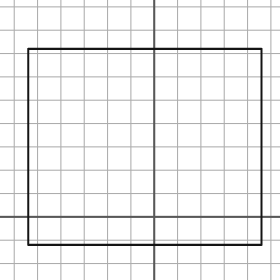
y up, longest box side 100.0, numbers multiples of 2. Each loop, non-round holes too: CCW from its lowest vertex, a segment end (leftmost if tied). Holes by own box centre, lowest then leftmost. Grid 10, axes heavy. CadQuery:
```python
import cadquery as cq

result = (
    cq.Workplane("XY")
    .moveTo(-54.0, -12.0)
    .lineTo(46.0, -12.0)
    .lineTo(46.0, 72.0)
    .lineTo(-54.0, 72.0)
    .close()
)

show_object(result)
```